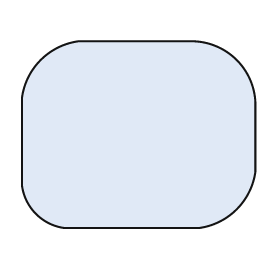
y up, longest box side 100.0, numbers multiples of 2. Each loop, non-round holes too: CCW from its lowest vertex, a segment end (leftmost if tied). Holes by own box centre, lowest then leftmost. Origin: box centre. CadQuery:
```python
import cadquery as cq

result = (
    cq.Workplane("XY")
    .moveTo(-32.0, -40.0)
    .lineTo(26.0, -40.0)
    .threePointArc((42.0, -32.0), (50.0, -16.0))
    .lineTo(50.0, 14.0)
    .threePointArc((42.0, 32.0), (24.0, 40.0))
    .lineTo(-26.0, 40.0)
    .threePointArc((-42.0, 32.0), (-50.0, 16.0))
    .lineTo(-50.0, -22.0)
    .threePointArc((-44.0, -34.0), (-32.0, -40.0))
    .close()
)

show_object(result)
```